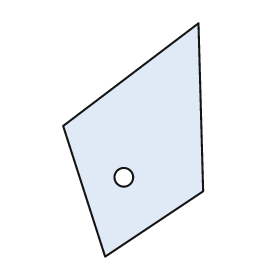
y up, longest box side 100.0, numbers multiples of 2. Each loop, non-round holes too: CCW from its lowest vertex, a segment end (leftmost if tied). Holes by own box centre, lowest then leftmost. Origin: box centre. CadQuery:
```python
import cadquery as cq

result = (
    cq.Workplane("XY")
    .moveTo(-12.0, -50.0)
    .lineTo(30.0, -22.0)
    .lineTo(28.0, 50.0)
    .lineTo(-30.0, 6.0)
    .close()
    .moveTo(-4.0, -16.0)
    .circle(4.0)
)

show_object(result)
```